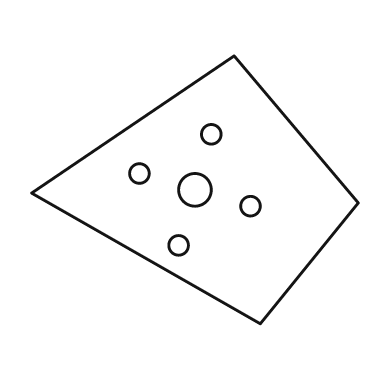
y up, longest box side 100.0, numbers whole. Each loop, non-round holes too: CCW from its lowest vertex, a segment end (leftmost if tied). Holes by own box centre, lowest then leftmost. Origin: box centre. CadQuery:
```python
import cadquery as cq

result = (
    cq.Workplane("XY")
    .moveTo(20.0, -41.0)
    .lineTo(50.0, -4.0)
    .lineTo(12.0, 41.0)
    .lineTo(-50.0, -1.0)
    .close()
    .moveTo(-5.0, -17.0)
    .circle(3.0)
    .moveTo(17.0, -5.0)
    .circle(3.0)
    .moveTo(0.0, 0.0)
    .circle(5.0)
    .moveTo(-17.0, 5.0)
    .circle(3.0)
    .moveTo(5.0, 17.0)
    .circle(3.0)
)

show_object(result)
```